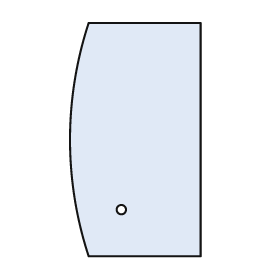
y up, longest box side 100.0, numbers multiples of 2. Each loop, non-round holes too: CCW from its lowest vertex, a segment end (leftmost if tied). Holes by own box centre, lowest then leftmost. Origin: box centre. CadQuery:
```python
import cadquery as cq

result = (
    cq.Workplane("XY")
    .moveTo(-20.0, -50.0)
    .lineTo(28.0, -50.0)
    .lineTo(28.0, 50.0)
    .lineTo(-20.0, 50.0)
    .threePointArc((-28.0, 0.0), (-20.0, -50.0))
    .close()
    .moveTo(-6.0, -30.0)
    .circle(2.0)
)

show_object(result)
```